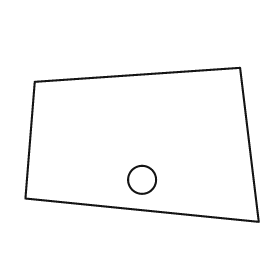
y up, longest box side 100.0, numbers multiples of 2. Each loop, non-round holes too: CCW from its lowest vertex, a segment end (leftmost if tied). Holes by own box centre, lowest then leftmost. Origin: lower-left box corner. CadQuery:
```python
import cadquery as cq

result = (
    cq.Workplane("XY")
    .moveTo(100.0, 0.0)
    .lineTo(92.0, 66.0)
    .lineTo(4.0, 60.0)
    .lineTo(0.0, 10.0)
    .close()
    .moveTo(50.0, 18.0)
    .circle(6.0)
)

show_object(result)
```